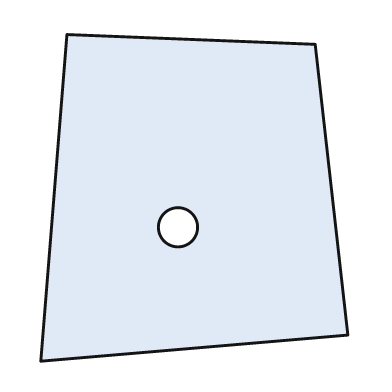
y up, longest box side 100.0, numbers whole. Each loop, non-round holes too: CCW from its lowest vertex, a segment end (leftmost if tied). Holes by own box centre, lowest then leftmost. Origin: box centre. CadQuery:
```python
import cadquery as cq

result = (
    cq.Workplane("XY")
    .moveTo(-47.0, -50.0)
    .lineTo(47.0, -42.0)
    .lineTo(37.0, 47.0)
    .lineTo(-39.0, 50.0)
    .close()
    .moveTo(-5.0, -9.0)
    .circle(6.0)
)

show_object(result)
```